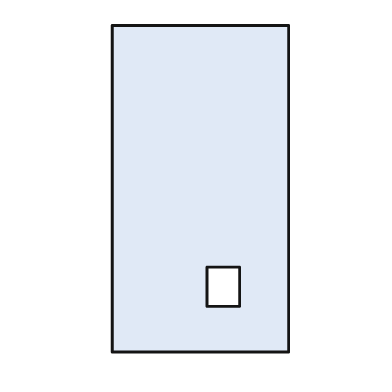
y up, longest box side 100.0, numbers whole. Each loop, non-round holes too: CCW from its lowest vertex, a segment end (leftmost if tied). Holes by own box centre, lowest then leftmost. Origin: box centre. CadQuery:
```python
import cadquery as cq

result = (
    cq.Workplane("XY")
    .moveTo(-27.0, -50.0)
    .lineTo(27.0, -50.0)
    .lineTo(27.0, 50.0)
    .lineTo(-27.0, 50.0)
    .close()
    .moveTo(2.0, -36.0)
    .lineTo(12.0, -36.0)
    .lineTo(12.0, -24.0)
    .lineTo(2.0, -24.0)
    .close()
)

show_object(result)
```